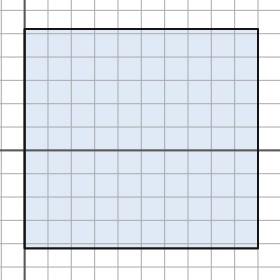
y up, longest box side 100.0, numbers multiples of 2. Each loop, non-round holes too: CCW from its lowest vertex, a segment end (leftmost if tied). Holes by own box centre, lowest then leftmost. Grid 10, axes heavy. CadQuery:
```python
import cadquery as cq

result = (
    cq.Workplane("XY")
    .moveTo(0.0, -42.0)
    .lineTo(100.0, -42.0)
    .lineTo(100.0, 52.0)
    .lineTo(0.0, 52.0)
    .close()
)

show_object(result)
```